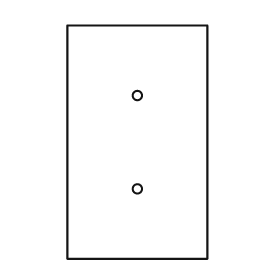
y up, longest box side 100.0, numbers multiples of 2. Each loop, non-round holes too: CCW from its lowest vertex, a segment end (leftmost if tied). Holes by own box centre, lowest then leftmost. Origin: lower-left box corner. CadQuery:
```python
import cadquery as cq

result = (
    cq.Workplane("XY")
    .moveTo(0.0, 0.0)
    .lineTo(60.0, 0.0)
    .lineTo(60.0, 100.0)
    .lineTo(0.0, 100.0)
    .close()
    .moveTo(30.0, 30.0)
    .circle(2.0)
    .moveTo(30.0, 70.0)
    .circle(2.0)
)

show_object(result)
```